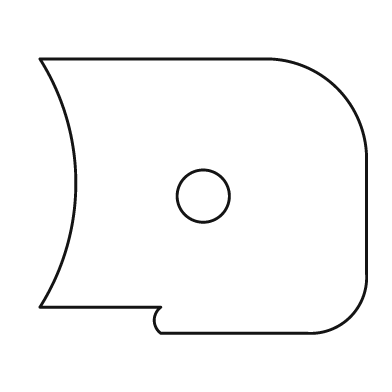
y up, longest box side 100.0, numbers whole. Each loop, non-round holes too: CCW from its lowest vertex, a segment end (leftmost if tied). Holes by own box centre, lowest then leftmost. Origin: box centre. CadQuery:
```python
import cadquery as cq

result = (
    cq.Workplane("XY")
    .moveTo(-13.0, -42.0)
    .lineTo(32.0, -42.0)
    .threePointArc((45.0, -37.0), (50.0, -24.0))
    .lineTo(50.0, 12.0)
    .threePointArc((41.0, 33.0), (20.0, 42.0))
    .lineTo(-50.0, 42.0)
    .threePointArc((-39.0, 4.0), (-50.0, -34.0))
    .lineTo(-13.0, -34.0)
    .threePointArc((-15.0, -38.0), (-13.0, -42.0))
    .close()
    .moveTo(0.0, 0.0)
    .circle(8.0)
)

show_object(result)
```